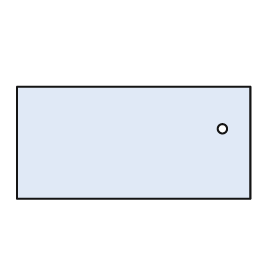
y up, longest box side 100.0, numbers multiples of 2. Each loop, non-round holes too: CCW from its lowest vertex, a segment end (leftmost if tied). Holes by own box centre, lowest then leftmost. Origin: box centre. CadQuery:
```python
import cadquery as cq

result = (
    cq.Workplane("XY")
    .moveTo(-50.0, -24.0)
    .lineTo(50.0, -24.0)
    .lineTo(50.0, 24.0)
    .lineTo(-50.0, 24.0)
    .close()
    .moveTo(38.0, 6.0)
    .circle(2.0)
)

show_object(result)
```